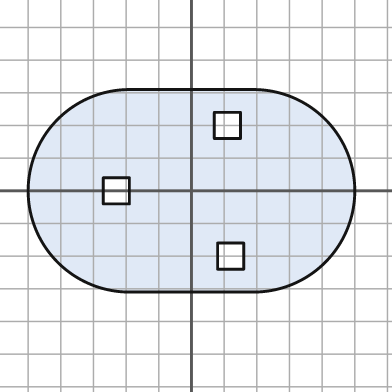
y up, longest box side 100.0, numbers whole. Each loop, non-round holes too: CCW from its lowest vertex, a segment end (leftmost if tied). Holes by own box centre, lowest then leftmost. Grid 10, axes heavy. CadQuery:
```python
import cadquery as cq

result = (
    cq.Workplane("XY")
    .moveTo(-19.0, -31.0)
    .lineTo(19.0, -31.0)
    .threePointArc((50.0, 0.0), (19.0, 31.0))
    .lineTo(-19.0, 31.0)
    .threePointArc((-50.0, 0.0), (-19.0, -31.0))
    .close()
    .moveTo(8.0, -24.0)
    .lineTo(16.0, -24.0)
    .lineTo(16.0, -16.0)
    .lineTo(8.0, -16.0)
    .close()
    .moveTo(-27.0, -4.0)
    .lineTo(-19.0, -4.0)
    .lineTo(-19.0, 4.0)
    .lineTo(-27.0, 4.0)
    .close()
    .moveTo(7.0, 16.0)
    .lineTo(15.0, 16.0)
    .lineTo(15.0, 24.0)
    .lineTo(7.0, 24.0)
    .close()
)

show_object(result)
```